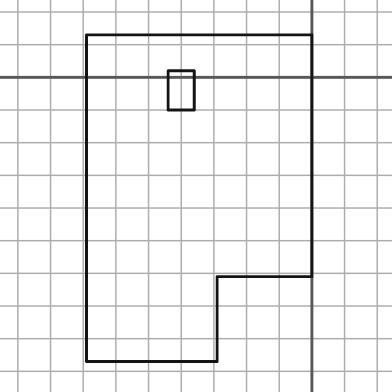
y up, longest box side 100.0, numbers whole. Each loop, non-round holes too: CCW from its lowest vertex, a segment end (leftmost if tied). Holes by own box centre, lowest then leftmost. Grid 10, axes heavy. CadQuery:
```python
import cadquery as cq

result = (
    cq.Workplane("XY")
    .moveTo(-69.0, -87.0)
    .lineTo(-29.0, -87.0)
    .lineTo(-29.0, -61.0)
    .lineTo(0.0, -61.0)
    .lineTo(0.0, 13.0)
    .lineTo(-69.0, 13.0)
    .close()
    .moveTo(-44.0, -10.0)
    .lineTo(-36.0, -10.0)
    .lineTo(-36.0, 2.0)
    .lineTo(-44.0, 2.0)
    .close()
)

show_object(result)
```